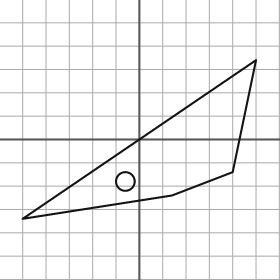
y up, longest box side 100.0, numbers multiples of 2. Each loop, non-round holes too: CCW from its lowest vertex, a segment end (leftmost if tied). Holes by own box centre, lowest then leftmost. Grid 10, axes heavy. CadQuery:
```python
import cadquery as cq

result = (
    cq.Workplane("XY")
    .moveTo(-50.0, -34.0)
    .lineTo(14.0, -24.0)
    .lineTo(40.0, -14.0)
    .lineTo(50.0, 34.0)
    .close()
    .moveTo(-6.0, -18.0)
    .circle(4.0)
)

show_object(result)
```